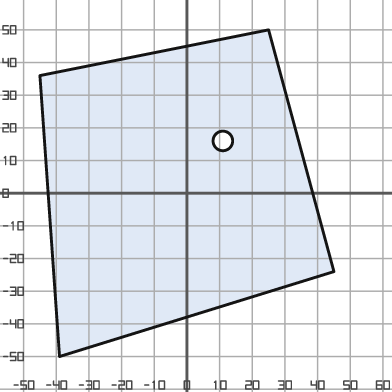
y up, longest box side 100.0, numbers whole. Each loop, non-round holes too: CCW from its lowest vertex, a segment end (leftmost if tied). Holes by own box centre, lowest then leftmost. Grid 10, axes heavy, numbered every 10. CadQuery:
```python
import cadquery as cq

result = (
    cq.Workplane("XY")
    .moveTo(-39.0, -50.0)
    .lineTo(45.0, -24.0)
    .lineTo(25.0, 50.0)
    .lineTo(-45.0, 36.0)
    .close()
    .moveTo(11.0, 16.0)
    .circle(3.0)
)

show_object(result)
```